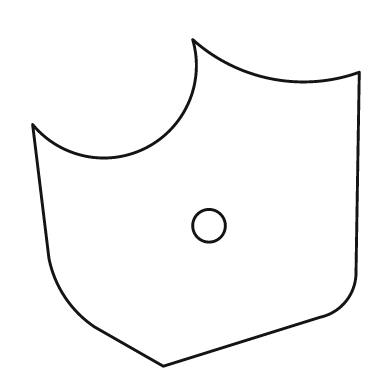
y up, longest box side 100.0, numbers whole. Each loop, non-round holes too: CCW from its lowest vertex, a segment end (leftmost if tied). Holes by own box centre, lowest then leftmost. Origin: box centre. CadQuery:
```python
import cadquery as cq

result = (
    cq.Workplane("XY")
    .moveTo(-10.0, -50.0)
    .lineTo(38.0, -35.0)
    .threePointArc((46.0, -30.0), (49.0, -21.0))
    .lineTo(50.0, 40.0)
    .threePointArc((23.0, 38.0), (-1.0, 50.0))
    .threePointArc((-15.0, 17.0), (-50.0, 24.0))
    .lineTo(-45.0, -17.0)
    .threePointArc((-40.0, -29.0), (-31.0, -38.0))
    .close()
    .moveTo(4.0, -7.0)
    .circle(5.0)
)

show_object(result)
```